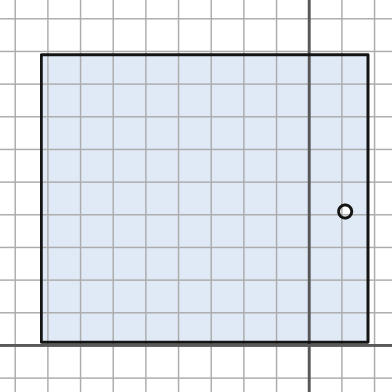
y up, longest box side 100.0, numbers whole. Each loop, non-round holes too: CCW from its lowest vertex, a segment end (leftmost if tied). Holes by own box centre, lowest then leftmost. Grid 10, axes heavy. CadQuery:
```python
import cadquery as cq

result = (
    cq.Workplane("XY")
    .moveTo(-82.0, 1.0)
    .lineTo(18.0, 1.0)
    .lineTo(18.0, 89.0)
    .lineTo(-82.0, 89.0)
    .close()
    .moveTo(11.0, 41.0)
    .circle(2.0)
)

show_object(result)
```